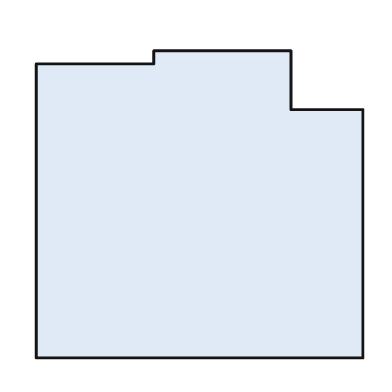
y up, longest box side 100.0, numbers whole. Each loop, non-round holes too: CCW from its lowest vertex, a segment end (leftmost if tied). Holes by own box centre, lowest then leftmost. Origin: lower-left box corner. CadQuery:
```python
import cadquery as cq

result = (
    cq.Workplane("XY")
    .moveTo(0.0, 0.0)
    .lineTo(100.0, 0.0)
    .lineTo(100.0, 76.0)
    .lineTo(78.0, 76.0)
    .lineTo(78.0, 94.0)
    .lineTo(36.0, 94.0)
    .lineTo(36.0, 90.0)
    .lineTo(0.0, 90.0)
    .close()
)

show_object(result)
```